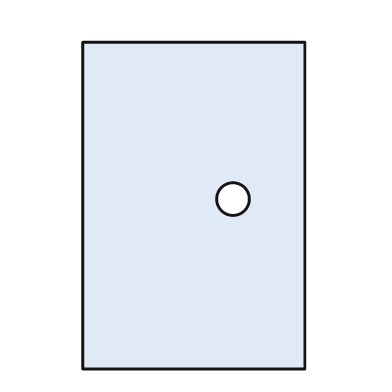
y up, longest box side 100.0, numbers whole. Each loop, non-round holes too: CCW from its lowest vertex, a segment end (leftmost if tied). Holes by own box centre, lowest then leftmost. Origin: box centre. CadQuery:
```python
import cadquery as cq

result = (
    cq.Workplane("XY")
    .moveTo(-34.0, -50.0)
    .lineTo(34.0, -50.0)
    .lineTo(34.0, 50.0)
    .lineTo(-34.0, 50.0)
    .close()
    .moveTo(12.0, 2.0)
    .circle(5.0)
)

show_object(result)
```